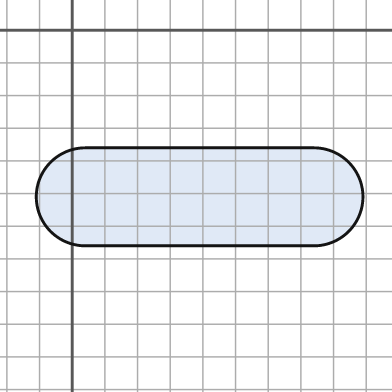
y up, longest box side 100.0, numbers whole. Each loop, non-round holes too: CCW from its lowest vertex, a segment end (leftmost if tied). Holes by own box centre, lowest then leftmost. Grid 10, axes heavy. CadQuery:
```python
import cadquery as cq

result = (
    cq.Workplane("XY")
    .moveTo(4.0, -66.0)
    .lineTo(74.0, -66.0)
    .threePointArc((89.0, -51.0), (74.0, -36.0))
    .lineTo(4.0, -36.0)
    .threePointArc((-11.0, -51.0), (4.0, -66.0))
    .close()
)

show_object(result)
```